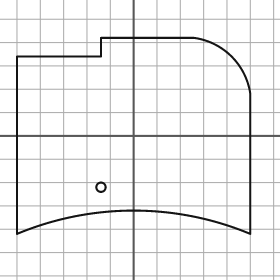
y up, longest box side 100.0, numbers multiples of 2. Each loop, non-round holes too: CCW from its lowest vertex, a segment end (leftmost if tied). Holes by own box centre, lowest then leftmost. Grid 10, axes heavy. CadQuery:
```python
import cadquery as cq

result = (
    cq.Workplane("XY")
    .moveTo(-50.0, -42.0)
    .threePointArc((0.0, -32.0), (50.0, -42.0))
    .lineTo(50.0, 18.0)
    .threePointArc((42.0, 34.0), (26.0, 42.0))
    .lineTo(-14.0, 42.0)
    .lineTo(-14.0, 34.0)
    .lineTo(-50.0, 34.0)
    .close()
    .moveTo(-14.0, -22.0)
    .circle(2.0)
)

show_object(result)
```